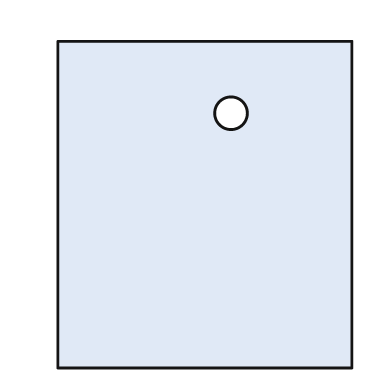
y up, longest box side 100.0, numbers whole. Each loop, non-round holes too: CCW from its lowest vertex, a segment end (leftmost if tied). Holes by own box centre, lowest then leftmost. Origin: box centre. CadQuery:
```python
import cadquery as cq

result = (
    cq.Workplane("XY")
    .moveTo(-45.0, -50.0)
    .lineTo(45.0, -50.0)
    .lineTo(45.0, 50.0)
    .lineTo(-45.0, 50.0)
    .close()
    .moveTo(8.0, 28.0)
    .circle(5.0)
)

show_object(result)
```